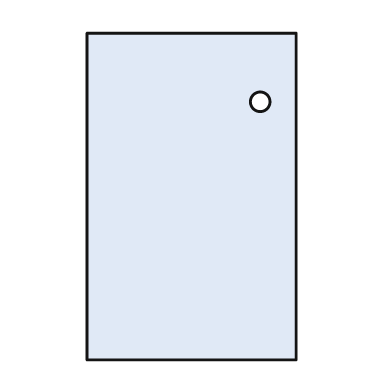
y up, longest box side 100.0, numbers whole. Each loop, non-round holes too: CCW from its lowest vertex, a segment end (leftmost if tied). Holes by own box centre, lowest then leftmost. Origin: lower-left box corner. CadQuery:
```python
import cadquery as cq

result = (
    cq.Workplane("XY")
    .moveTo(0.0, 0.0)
    .lineTo(64.0, 0.0)
    .lineTo(64.0, 100.0)
    .lineTo(0.0, 100.0)
    .close()
    .moveTo(53.0, 79.0)
    .circle(3.0)
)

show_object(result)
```